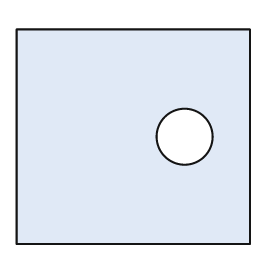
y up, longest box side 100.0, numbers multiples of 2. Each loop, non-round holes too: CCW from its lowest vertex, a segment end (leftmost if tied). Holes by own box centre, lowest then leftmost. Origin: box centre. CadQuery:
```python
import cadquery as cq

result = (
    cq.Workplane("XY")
    .moveTo(-50.0, -46.0)
    .lineTo(50.0, -46.0)
    .lineTo(50.0, 46.0)
    .lineTo(-50.0, 46.0)
    .close()
    .moveTo(22.0, 0.0)
    .circle(12.0)
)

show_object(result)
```